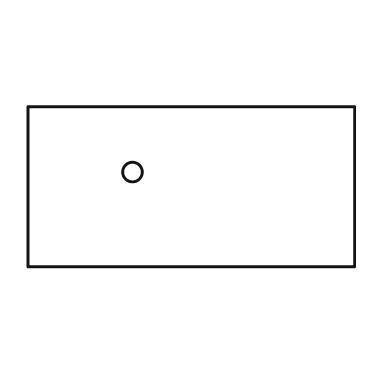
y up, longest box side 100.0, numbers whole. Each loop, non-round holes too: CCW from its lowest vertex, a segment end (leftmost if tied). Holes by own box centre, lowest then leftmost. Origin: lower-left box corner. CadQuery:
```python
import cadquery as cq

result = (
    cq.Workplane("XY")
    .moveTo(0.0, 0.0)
    .lineTo(100.0, 0.0)
    .lineTo(100.0, 49.0)
    .lineTo(0.0, 49.0)
    .close()
    .moveTo(32.0, 29.0)
    .circle(3.0)
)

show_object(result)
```